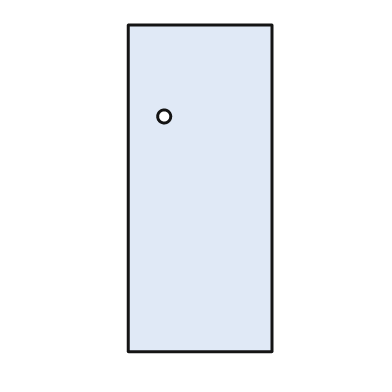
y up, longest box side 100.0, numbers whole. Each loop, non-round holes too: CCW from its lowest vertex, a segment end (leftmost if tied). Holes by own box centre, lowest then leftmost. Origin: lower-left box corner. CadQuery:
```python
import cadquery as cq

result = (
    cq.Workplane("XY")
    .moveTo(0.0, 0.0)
    .lineTo(44.0, 0.0)
    .lineTo(44.0, 100.0)
    .lineTo(0.0, 100.0)
    .close()
    .moveTo(11.0, 72.0)
    .circle(2.0)
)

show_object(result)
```